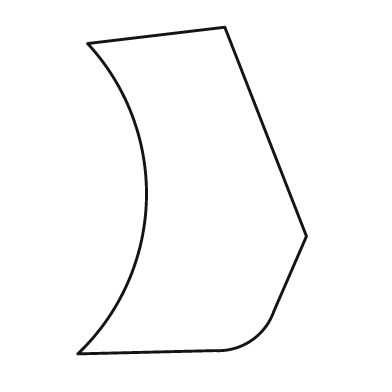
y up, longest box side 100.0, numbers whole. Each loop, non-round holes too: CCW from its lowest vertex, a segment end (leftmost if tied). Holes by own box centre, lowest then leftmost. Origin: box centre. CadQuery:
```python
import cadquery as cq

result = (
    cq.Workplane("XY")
    .moveTo(-35.0, -50.0)
    .lineTo(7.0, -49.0)
    .threePointArc((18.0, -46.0), (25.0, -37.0))
    .lineTo(35.0, -14.0)
    .lineTo(10.0, 50.0)
    .lineTo(-32.0, 45.0)
    .threePointArc((-14.0, -3.0), (-35.0, -50.0))
    .close()
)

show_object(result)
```